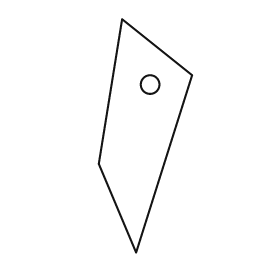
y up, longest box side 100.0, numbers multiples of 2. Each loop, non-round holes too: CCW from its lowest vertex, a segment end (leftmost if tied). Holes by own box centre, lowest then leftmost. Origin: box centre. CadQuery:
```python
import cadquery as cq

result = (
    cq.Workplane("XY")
    .moveTo(-4.0, -50.0)
    .lineTo(20.0, 26.0)
    .lineTo(-10.0, 50.0)
    .lineTo(-20.0, -12.0)
    .close()
    .moveTo(2.0, 22.0)
    .circle(4.0)
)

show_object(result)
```